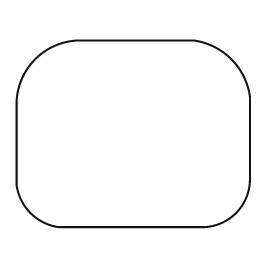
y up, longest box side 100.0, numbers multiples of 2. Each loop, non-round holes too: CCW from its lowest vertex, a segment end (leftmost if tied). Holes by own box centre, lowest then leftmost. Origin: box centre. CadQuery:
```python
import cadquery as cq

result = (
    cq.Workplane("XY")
    .moveTo(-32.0, -40.0)
    .lineTo(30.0, -40.0)
    .threePointArc((44.0, -34.0), (50.0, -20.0))
    .lineTo(50.0, 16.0)
    .threePointArc((42.0, 32.0), (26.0, 40.0))
    .lineTo(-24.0, 40.0)
    .threePointArc((-42.0, 32.0), (-50.0, 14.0))
    .lineTo(-50.0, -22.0)
    .threePointArc((-44.0, -34.0), (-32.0, -40.0))
    .close()
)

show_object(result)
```